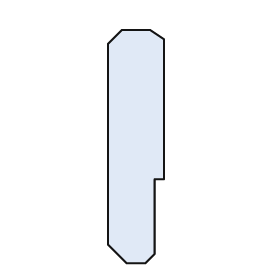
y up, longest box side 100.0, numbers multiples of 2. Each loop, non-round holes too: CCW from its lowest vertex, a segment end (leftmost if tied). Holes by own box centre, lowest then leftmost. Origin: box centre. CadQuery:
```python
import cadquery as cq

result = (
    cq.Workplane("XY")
    .moveTo(-4.0, -50.0)
    .lineTo(4.0, -50.0)
    .lineTo(8.0, -46.0)
    .lineTo(8.0, -14.0)
    .lineTo(12.0, -14.0)
    .lineTo(12.0, 46.0)
    .lineTo(6.0, 50.0)
    .lineTo(-6.0, 50.0)
    .lineTo(-12.0, 44.0)
    .lineTo(-12.0, -42.0)
    .close()
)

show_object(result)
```